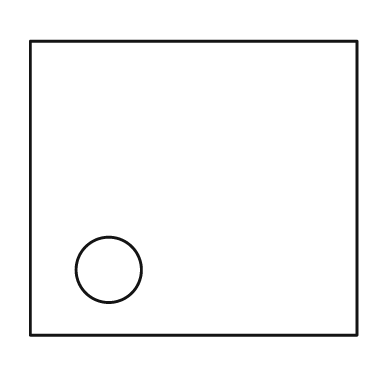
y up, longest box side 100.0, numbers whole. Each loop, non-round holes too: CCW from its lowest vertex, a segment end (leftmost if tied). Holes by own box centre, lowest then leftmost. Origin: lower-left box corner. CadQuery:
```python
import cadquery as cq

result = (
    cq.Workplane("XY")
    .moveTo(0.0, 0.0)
    .lineTo(100.0, 0.0)
    .lineTo(100.0, 90.0)
    .lineTo(0.0, 90.0)
    .close()
    .moveTo(24.0, 20.0)
    .circle(10.0)
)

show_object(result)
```